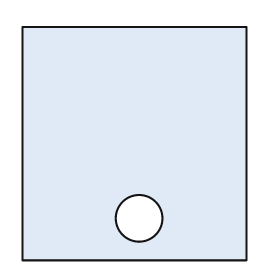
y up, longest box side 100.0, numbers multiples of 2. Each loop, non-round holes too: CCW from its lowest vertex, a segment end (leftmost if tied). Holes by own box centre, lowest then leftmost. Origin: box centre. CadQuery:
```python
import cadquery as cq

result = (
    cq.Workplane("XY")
    .moveTo(-48.0, -50.0)
    .lineTo(48.0, -50.0)
    .lineTo(48.0, 50.0)
    .lineTo(-48.0, 50.0)
    .close()
    .moveTo(2.0, -32.0)
    .circle(10.0)
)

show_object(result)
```